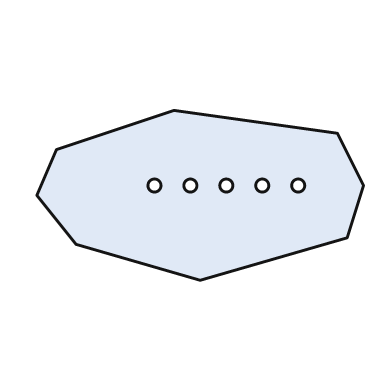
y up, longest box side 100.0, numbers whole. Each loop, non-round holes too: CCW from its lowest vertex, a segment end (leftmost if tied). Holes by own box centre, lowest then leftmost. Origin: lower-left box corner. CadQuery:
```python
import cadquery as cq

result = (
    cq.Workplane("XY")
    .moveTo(50.0, 0.0)
    .lineTo(95.0, 13.0)
    .lineTo(100.0, 29.0)
    .lineTo(92.0, 45.0)
    .lineTo(42.0, 52.0)
    .lineTo(6.0, 40.0)
    .lineTo(0.0, 26.0)
    .lineTo(12.0, 11.0)
    .close()
    .moveTo(36.0, 29.0)
    .circle(2.0)
    .moveTo(47.0, 29.0)
    .circle(2.0)
    .moveTo(58.0, 29.0)
    .circle(2.0)
    .moveTo(69.0, 29.0)
    .circle(2.0)
    .moveTo(80.0, 29.0)
    .circle(2.0)
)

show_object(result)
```